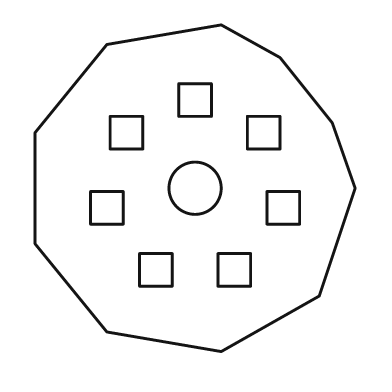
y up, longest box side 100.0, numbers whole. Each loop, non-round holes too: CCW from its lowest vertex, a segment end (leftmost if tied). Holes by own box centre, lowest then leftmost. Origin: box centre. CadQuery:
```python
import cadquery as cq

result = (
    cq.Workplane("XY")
    .moveTo(8.0, -50.0)
    .lineTo(38.0, -33.0)
    .lineTo(49.0, 0.0)
    .lineTo(42.0, 20.0)
    .lineTo(26.0, 40.0)
    .lineTo(8.0, 50.0)
    .lineTo(-27.0, 44.0)
    .lineTo(-49.0, 17.0)
    .lineTo(-49.0, -17.0)
    .lineTo(-27.0, -44.0)
    .close()
    .moveTo(-17.0, -30.0)
    .lineTo(-7.0, -30.0)
    .lineTo(-7.0, -20.0)
    .lineTo(-17.0, -20.0)
    .close()
    .moveTo(7.0, -30.0)
    .lineTo(17.0, -30.0)
    .lineTo(17.0, -20.0)
    .lineTo(7.0, -20.0)
    .close()
    .moveTo(-32.0, -11.0)
    .lineTo(-22.0, -11.0)
    .lineTo(-22.0, -1.0)
    .lineTo(-32.0, -1.0)
    .close()
    .moveTo(22.0, -11.0)
    .lineTo(32.0, -11.0)
    .lineTo(32.0, -1.0)
    .lineTo(22.0, -1.0)
    .close()
    .moveTo(0.0, 0.0)
    .circle(8.0)
    .moveTo(-26.0, 12.0)
    .lineTo(-16.0, 12.0)
    .lineTo(-16.0, 22.0)
    .lineTo(-26.0, 22.0)
    .close()
    .moveTo(16.0, 12.0)
    .lineTo(26.0, 12.0)
    .lineTo(26.0, 22.0)
    .lineTo(16.0, 22.0)
    .close()
    .moveTo(-5.0, 22.0)
    .lineTo(5.0, 22.0)
    .lineTo(5.0, 32.0)
    .lineTo(-5.0, 32.0)
    .close()
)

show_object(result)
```